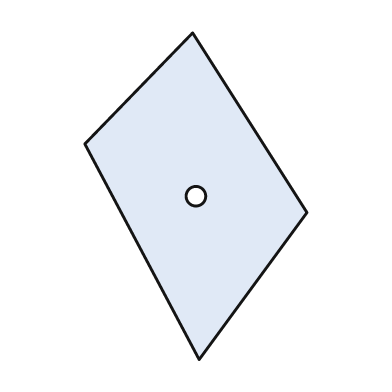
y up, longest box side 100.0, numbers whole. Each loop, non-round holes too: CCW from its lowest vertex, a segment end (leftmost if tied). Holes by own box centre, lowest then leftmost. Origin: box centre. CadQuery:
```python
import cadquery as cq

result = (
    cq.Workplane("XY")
    .moveTo(1.0, -50.0)
    .lineTo(34.0, -5.0)
    .lineTo(-1.0, 50.0)
    .lineTo(-34.0, 16.0)
    .close()
    .moveTo(0.0, 0.0)
    .circle(3.0)
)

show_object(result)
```